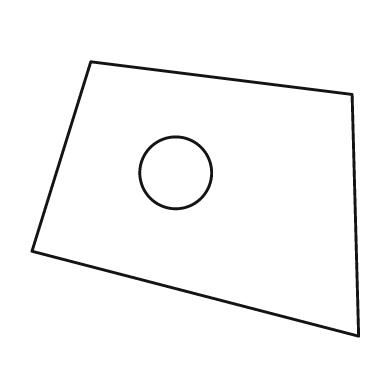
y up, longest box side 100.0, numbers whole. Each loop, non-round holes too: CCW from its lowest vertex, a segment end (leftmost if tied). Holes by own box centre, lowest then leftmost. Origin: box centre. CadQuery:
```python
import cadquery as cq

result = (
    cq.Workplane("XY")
    .moveTo(50.0, -42.0)
    .lineTo(48.0, 32.0)
    .lineTo(-32.0, 42.0)
    .lineTo(-50.0, -16.0)
    .close()
    .moveTo(-6.0, 8.0)
    .circle(11.0)
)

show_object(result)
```